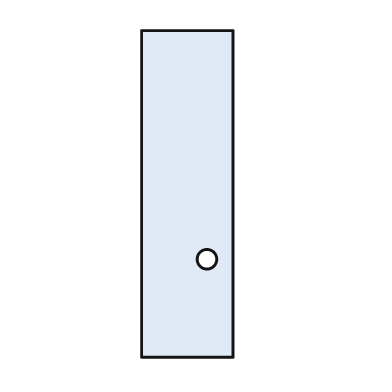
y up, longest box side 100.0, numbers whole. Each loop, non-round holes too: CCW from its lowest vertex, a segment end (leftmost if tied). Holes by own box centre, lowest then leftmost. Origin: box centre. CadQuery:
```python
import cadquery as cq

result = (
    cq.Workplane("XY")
    .moveTo(-14.0, -50.0)
    .lineTo(14.0, -50.0)
    .lineTo(14.0, 50.0)
    .lineTo(-14.0, 50.0)
    .close()
    .moveTo(6.0, -20.0)
    .circle(3.0)
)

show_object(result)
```